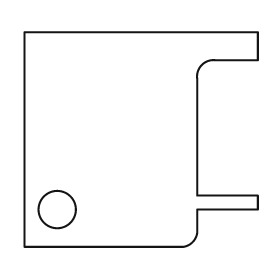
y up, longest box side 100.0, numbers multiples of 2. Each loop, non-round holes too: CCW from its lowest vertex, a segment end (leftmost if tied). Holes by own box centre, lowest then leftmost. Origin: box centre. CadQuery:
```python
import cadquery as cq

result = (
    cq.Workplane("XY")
    .moveTo(-50.0, -46.0)
    .lineTo(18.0, -46.0)
    .threePointArc((22.0, -44.0), (24.0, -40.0))
    .lineTo(24.0, -30.0)
    .lineTo(50.0, -30.0)
    .lineTo(50.0, -24.0)
    .lineTo(24.0, -24.0)
    .lineTo(24.0, 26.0)
    .threePointArc((26.0, 32.0), (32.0, 34.0))
    .lineTo(50.0, 34.0)
    .lineTo(50.0, 46.0)
    .lineTo(-50.0, 46.0)
    .close()
    .moveTo(-36.0, -30.0)
    .circle(8.0)
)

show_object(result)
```